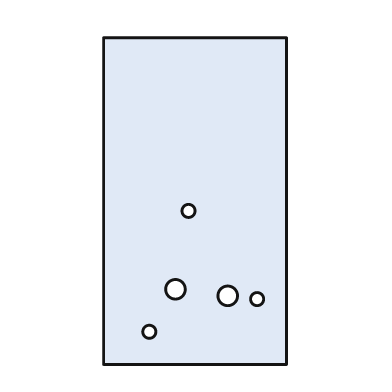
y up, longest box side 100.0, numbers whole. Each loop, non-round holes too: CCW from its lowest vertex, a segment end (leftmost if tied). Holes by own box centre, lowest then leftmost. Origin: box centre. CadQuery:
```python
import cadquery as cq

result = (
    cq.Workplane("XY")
    .moveTo(-28.0, -50.0)
    .lineTo(28.0, -50.0)
    .lineTo(28.0, 50.0)
    .lineTo(-28.0, 50.0)
    .close()
    .moveTo(-14.0, -40.0)
    .circle(2.0)
    .moveTo(19.0, -30.0)
    .circle(2.0)
    .moveTo(10.0, -29.0)
    .circle(3.0)
    .moveTo(-6.0, -27.0)
    .circle(3.0)
    .moveTo(-2.0, -3.0)
    .circle(2.0)
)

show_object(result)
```